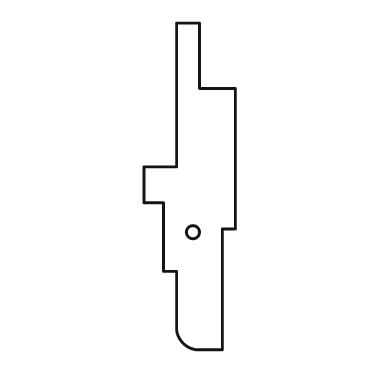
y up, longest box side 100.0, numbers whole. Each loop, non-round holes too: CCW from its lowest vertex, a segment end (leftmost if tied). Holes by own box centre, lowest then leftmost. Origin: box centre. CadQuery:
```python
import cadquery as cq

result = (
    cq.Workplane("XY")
    .moveTo(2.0, -50.0)
    .lineTo(10.0, -50.0)
    .lineTo(10.0, -13.0)
    .lineTo(14.0, -13.0)
    .lineTo(14.0, 30.0)
    .lineTo(3.0, 30.0)
    .lineTo(3.0, 50.0)
    .lineTo(-4.0, 50.0)
    .lineTo(-4.0, 6.0)
    .lineTo(-14.0, 6.0)
    .lineTo(-14.0, -5.0)
    .lineTo(-8.0, -5.0)
    .lineTo(-8.0, -26.0)
    .lineTo(-4.0, -26.0)
    .lineTo(-4.0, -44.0)
    .threePointArc((-2.0, -48.0), (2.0, -50.0))
    .close()
    .moveTo(1.0, -14.0)
    .circle(2.0)
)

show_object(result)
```